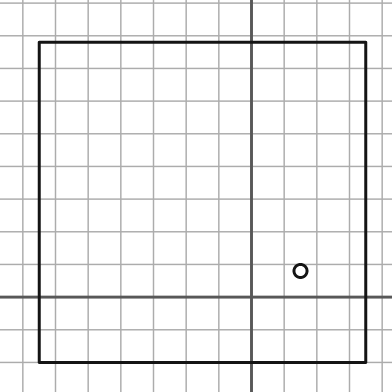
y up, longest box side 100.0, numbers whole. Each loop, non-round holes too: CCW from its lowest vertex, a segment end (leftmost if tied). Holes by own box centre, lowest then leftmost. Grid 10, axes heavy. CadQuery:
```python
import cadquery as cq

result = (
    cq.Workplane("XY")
    .moveTo(-65.0, -20.0)
    .lineTo(35.0, -20.0)
    .lineTo(35.0, 78.0)
    .lineTo(-65.0, 78.0)
    .close()
    .moveTo(15.0, 8.0)
    .circle(2.0)
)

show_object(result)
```